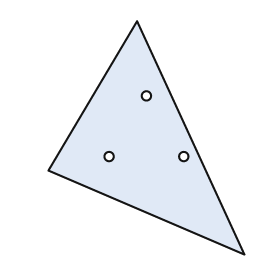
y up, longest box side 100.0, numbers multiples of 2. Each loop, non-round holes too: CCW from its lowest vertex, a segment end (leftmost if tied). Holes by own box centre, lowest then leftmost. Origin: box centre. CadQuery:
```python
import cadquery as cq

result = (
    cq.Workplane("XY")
    .moveTo(42.0, -50.0)
    .lineTo(-4.0, 50.0)
    .lineTo(-42.0, -14.0)
    .close()
    .moveTo(-16.0, -8.0)
    .circle(2.0)
    .moveTo(16.0, -8.0)
    .circle(2.0)
    .moveTo(0.0, 18.0)
    .circle(2.0)
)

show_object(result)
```